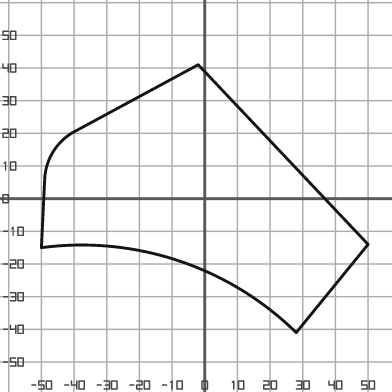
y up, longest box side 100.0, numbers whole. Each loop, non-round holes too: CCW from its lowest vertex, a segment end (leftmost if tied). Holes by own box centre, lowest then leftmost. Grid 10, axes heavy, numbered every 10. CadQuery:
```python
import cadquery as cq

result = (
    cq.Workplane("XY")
    .moveTo(28.0, -41.0)
    .lineTo(50.0, -14.0)
    .lineTo(-2.0, 41.0)
    .lineTo(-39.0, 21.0)
    .threePointArc((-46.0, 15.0), (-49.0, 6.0))
    .lineTo(-50.0, -15.0)
    .threePointArc((-8.0, -19.0), (28.0, -41.0))
    .close()
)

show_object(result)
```